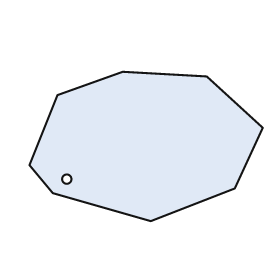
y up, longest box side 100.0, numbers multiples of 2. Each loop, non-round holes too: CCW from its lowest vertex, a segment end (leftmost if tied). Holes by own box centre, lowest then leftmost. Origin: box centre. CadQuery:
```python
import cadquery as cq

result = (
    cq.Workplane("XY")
    .moveTo(2.0, -32.0)
    .lineTo(38.0, -18.0)
    .lineTo(50.0, 8.0)
    .lineTo(26.0, 30.0)
    .lineTo(-10.0, 32.0)
    .lineTo(-38.0, 22.0)
    .lineTo(-50.0, -8.0)
    .lineTo(-40.0, -20.0)
    .close()
    .moveTo(-34.0, -14.0)
    .circle(2.0)
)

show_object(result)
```